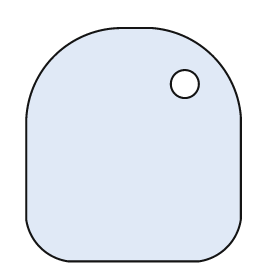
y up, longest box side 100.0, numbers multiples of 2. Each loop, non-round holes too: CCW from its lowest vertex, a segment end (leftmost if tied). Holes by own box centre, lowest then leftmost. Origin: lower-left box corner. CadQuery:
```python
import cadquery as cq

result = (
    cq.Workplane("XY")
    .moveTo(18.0, 0.0)
    .lineTo(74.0, 0.0)
    .threePointArc((86.0, 6.0), (92.0, 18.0))
    .lineTo(92.0, 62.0)
    .threePointArc((80.0, 88.0), (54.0, 100.0))
    .lineTo(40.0, 100.0)
    .threePointArc((12.0, 88.0), (0.0, 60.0))
    .lineTo(0.0, 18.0)
    .threePointArc((6.0, 6.0), (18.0, 0.0))
    .close()
    .moveTo(68.0, 76.0)
    .circle(6.0)
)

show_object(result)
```